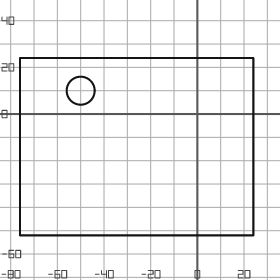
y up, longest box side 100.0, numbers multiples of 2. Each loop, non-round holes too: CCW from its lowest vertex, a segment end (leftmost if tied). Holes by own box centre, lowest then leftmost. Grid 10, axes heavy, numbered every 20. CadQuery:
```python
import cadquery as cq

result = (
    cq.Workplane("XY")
    .moveTo(-76.0, -52.0)
    .lineTo(24.0, -52.0)
    .lineTo(24.0, 24.0)
    .lineTo(-76.0, 24.0)
    .close()
    .moveTo(-50.0, 10.0)
    .circle(6.0)
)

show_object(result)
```